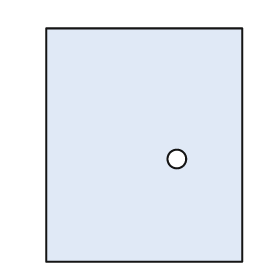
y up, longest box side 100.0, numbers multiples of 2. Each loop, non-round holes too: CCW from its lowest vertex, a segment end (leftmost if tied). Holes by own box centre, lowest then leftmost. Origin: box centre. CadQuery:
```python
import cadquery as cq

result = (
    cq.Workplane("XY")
    .moveTo(-42.0, -50.0)
    .lineTo(42.0, -50.0)
    .lineTo(42.0, 50.0)
    .lineTo(-42.0, 50.0)
    .close()
    .moveTo(14.0, -6.0)
    .circle(4.0)
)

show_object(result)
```